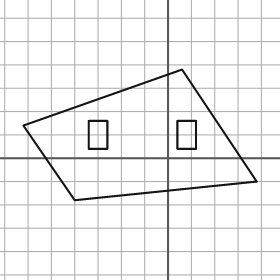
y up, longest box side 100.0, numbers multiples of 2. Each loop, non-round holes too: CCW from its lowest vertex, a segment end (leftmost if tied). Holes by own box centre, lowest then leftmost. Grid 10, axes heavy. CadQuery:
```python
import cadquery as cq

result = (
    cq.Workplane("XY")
    .moveTo(-40.0, -18.0)
    .lineTo(38.0, -10.0)
    .lineTo(6.0, 38.0)
    .lineTo(-62.0, 14.0)
    .close()
    .moveTo(-34.0, 4.0)
    .lineTo(-26.0, 4.0)
    .lineTo(-26.0, 16.0)
    .lineTo(-34.0, 16.0)
    .close()
    .moveTo(4.0, 4.0)
    .lineTo(12.0, 4.0)
    .lineTo(12.0, 16.0)
    .lineTo(4.0, 16.0)
    .close()
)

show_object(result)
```